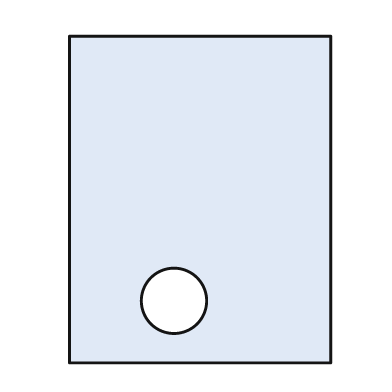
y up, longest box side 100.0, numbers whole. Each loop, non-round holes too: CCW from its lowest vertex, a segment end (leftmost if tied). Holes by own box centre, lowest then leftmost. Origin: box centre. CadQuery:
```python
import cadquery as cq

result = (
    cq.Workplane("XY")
    .moveTo(-40.0, -50.0)
    .lineTo(40.0, -50.0)
    .lineTo(40.0, 50.0)
    .lineTo(-40.0, 50.0)
    .close()
    .moveTo(-8.0, -31.0)
    .circle(10.0)
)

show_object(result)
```